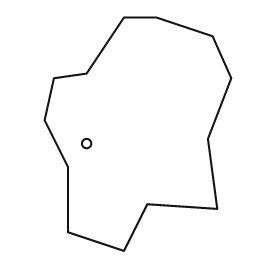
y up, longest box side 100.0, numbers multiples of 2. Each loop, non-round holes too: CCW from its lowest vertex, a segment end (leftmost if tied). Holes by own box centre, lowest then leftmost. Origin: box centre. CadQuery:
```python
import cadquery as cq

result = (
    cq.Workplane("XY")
    .moveTo(-6.0, -50.0)
    .lineTo(4.0, -30.0)
    .lineTo(34.0, -32.0)
    .lineTo(30.0, -2.0)
    .lineTo(40.0, 24.0)
    .lineTo(32.0, 42.0)
    .lineTo(8.0, 50.0)
    .lineTo(-6.0, 50.0)
    .lineTo(-22.0, 26.0)
    .lineTo(-36.0, 24.0)
    .lineTo(-40.0, 6.0)
    .lineTo(-30.0, -14.0)
    .lineTo(-30.0, -42.0)
    .close()
    .moveTo(-22.0, -4.0)
    .circle(2.0)
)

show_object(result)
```